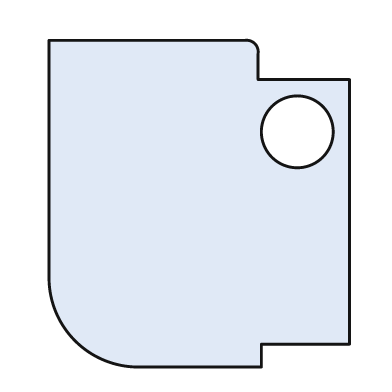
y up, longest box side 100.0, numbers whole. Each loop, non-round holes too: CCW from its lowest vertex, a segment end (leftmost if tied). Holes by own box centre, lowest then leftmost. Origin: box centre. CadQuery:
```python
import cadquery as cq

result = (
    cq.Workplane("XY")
    .moveTo(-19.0, -50.0)
    .lineTo(19.0, -50.0)
    .lineTo(19.0, -43.0)
    .lineTo(46.0, -43.0)
    .lineTo(46.0, 38.0)
    .lineTo(18.0, 38.0)
    .lineTo(18.0, 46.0)
    .threePointArc((17.0, 49.0), (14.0, 50.0))
    .lineTo(-46.0, 50.0)
    .lineTo(-46.0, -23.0)
    .threePointArc((-38.0, -42.0), (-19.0, -50.0))
    .close()
    .moveTo(30.0, 22.0)
    .circle(11.0)
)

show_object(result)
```